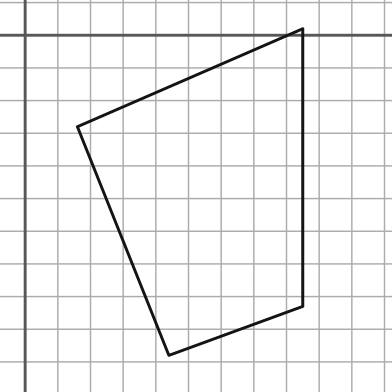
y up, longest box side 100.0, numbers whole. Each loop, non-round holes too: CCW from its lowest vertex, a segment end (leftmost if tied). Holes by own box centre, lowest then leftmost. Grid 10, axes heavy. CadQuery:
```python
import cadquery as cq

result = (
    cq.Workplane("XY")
    .moveTo(44.0, -98.0)
    .lineTo(85.0, -83.0)
    .lineTo(85.0, 2.0)
    .lineTo(16.0, -28.0)
    .close()
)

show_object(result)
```